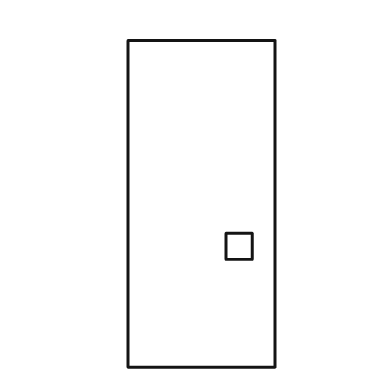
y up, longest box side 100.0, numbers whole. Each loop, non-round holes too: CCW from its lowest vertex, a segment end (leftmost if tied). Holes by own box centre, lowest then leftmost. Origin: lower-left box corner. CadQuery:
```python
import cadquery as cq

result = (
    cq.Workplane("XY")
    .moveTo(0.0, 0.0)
    .lineTo(45.0, 0.0)
    .lineTo(45.0, 100.0)
    .lineTo(0.0, 100.0)
    .close()
    .moveTo(30.0, 33.0)
    .lineTo(38.0, 33.0)
    .lineTo(38.0, 41.0)
    .lineTo(30.0, 41.0)
    .close()
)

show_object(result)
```